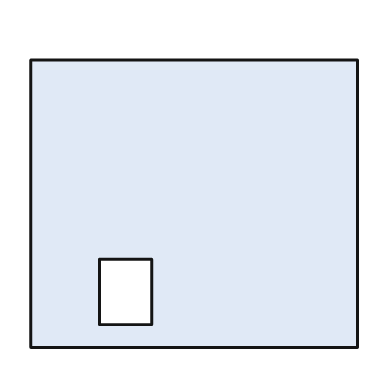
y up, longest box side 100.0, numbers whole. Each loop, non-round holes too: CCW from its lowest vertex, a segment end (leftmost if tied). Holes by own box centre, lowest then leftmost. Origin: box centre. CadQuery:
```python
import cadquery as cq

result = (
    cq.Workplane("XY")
    .moveTo(-50.0, -44.0)
    .lineTo(50.0, -44.0)
    .lineTo(50.0, 44.0)
    .lineTo(-50.0, 44.0)
    .close()
    .moveTo(-29.0, -37.0)
    .lineTo(-13.0, -37.0)
    .lineTo(-13.0, -17.0)
    .lineTo(-29.0, -17.0)
    .close()
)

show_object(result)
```